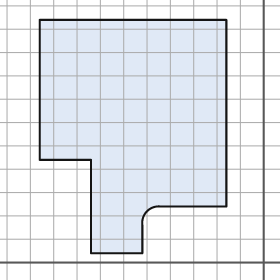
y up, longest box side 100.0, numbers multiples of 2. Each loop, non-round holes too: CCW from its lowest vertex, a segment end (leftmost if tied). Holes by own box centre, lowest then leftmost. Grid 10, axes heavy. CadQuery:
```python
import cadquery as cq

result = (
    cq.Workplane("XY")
    .moveTo(-74.0, 4.0)
    .lineTo(-52.0, 4.0)
    .lineTo(-52.0, 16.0)
    .threePointArc((-50.0, 22.0), (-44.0, 24.0))
    .lineTo(-16.0, 24.0)
    .lineTo(-16.0, 104.0)
    .lineTo(-96.0, 104.0)
    .lineTo(-96.0, 44.0)
    .lineTo(-74.0, 44.0)
    .close()
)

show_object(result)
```